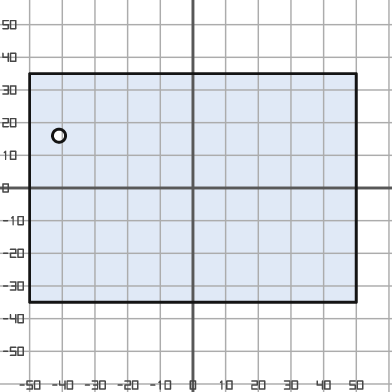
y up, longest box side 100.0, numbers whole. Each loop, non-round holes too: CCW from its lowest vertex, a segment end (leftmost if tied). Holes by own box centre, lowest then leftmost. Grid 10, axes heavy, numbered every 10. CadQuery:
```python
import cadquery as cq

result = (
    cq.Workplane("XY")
    .moveTo(-50.0, -35.0)
    .lineTo(50.0, -35.0)
    .lineTo(50.0, 35.0)
    .lineTo(-50.0, 35.0)
    .close()
    .moveTo(-41.0, 16.0)
    .circle(2.0)
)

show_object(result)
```